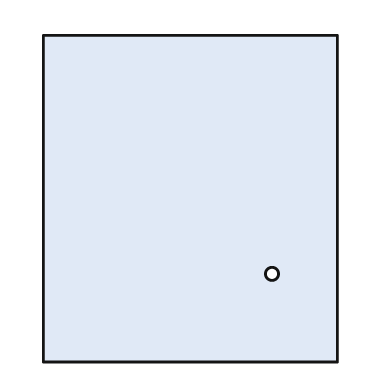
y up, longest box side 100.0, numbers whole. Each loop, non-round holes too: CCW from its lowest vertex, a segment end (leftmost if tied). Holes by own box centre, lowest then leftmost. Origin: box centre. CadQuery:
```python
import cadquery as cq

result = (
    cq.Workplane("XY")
    .moveTo(-45.0, -50.0)
    .lineTo(45.0, -50.0)
    .lineTo(45.0, 50.0)
    .lineTo(-45.0, 50.0)
    .close()
    .moveTo(25.0, -23.0)
    .circle(2.0)
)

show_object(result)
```